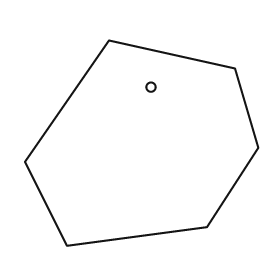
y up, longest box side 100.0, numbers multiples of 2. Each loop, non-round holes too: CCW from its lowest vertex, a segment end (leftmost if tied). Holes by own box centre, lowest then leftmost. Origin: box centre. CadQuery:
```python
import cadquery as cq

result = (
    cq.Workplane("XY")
    .moveTo(-32.0, -44.0)
    .lineTo(28.0, -36.0)
    .lineTo(50.0, -2.0)
    .lineTo(40.0, 32.0)
    .lineTo(-14.0, 44.0)
    .lineTo(-50.0, -8.0)
    .close()
    .moveTo(4.0, 24.0)
    .circle(2.0)
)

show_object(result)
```